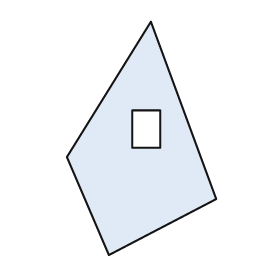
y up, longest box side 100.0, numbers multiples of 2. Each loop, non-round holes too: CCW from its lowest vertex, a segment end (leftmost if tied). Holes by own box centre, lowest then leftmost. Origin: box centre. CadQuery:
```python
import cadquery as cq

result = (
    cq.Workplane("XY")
    .moveTo(-14.0, -50.0)
    .lineTo(32.0, -26.0)
    .lineTo(4.0, 50.0)
    .lineTo(-32.0, -8.0)
    .close()
    .moveTo(-4.0, -4.0)
    .lineTo(8.0, -4.0)
    .lineTo(8.0, 12.0)
    .lineTo(-4.0, 12.0)
    .close()
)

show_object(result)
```